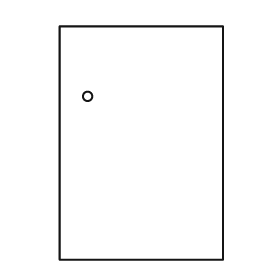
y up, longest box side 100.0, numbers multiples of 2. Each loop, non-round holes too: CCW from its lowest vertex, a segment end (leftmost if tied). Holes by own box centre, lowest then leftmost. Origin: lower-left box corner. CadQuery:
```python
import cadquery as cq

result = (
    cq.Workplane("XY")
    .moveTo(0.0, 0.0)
    .lineTo(70.0, 0.0)
    .lineTo(70.0, 100.0)
    .lineTo(0.0, 100.0)
    .close()
    .moveTo(12.0, 70.0)
    .circle(2.0)
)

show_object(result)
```